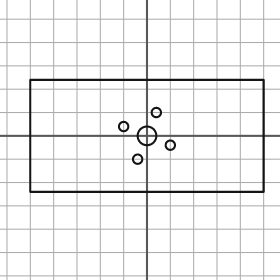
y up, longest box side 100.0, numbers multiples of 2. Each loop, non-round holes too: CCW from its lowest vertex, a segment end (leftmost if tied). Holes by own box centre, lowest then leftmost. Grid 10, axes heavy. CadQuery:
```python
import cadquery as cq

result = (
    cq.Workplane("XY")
    .moveTo(-50.0, -24.0)
    .lineTo(50.0, -24.0)
    .lineTo(50.0, 24.0)
    .lineTo(-50.0, 24.0)
    .close()
    .moveTo(-4.0, -10.0)
    .circle(2.0)
    .moveTo(10.0, -4.0)
    .circle(2.0)
    .moveTo(0.0, 0.0)
    .circle(4.0)
    .moveTo(-10.0, 4.0)
    .circle(2.0)
    .moveTo(4.0, 10.0)
    .circle(2.0)
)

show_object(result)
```